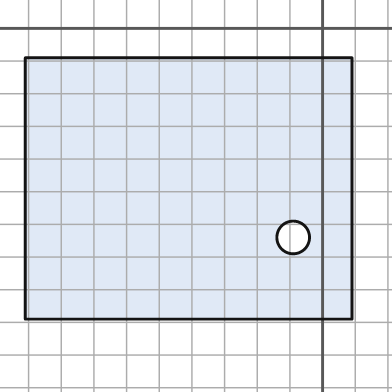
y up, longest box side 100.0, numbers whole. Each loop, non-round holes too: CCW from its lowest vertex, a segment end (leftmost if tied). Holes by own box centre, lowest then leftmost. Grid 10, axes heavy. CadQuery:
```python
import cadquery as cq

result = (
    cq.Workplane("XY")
    .moveTo(-91.0, -89.0)
    .lineTo(9.0, -89.0)
    .lineTo(9.0, -9.0)
    .lineTo(-91.0, -9.0)
    .close()
    .moveTo(-9.0, -64.0)
    .circle(5.0)
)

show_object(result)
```